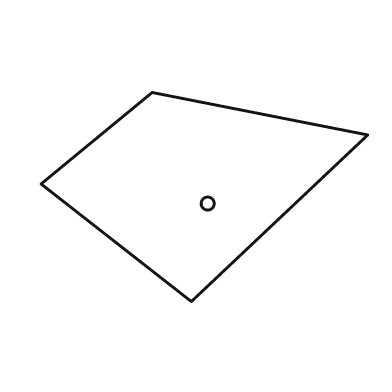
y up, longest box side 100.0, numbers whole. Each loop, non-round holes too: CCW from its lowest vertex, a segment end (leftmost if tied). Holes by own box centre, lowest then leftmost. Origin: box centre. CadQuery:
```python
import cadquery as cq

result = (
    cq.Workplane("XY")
    .moveTo(-4.0, -32.0)
    .lineTo(50.0, 19.0)
    .lineTo(-16.0, 32.0)
    .lineTo(-50.0, 4.0)
    .close()
    .moveTo(1.0, -2.0)
    .circle(2.0)
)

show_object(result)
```